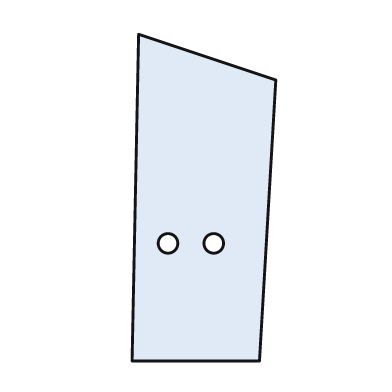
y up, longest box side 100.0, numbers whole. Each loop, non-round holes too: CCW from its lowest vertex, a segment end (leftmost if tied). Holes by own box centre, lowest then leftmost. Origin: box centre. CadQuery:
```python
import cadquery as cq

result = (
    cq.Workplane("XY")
    .moveTo(-22.0, -50.0)
    .lineTo(17.0, -50.0)
    .lineTo(22.0, 36.0)
    .lineTo(-20.0, 50.0)
    .close()
    .moveTo(-11.0, -14.0)
    .circle(3.0)
    .moveTo(3.0, -14.0)
    .circle(3.0)
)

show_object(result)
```